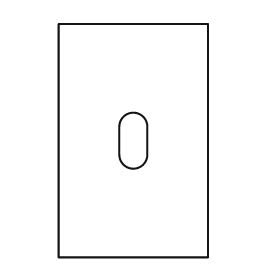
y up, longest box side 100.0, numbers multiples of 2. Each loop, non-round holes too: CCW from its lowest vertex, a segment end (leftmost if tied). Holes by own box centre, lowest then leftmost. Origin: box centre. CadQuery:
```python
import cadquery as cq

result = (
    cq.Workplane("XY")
    .moveTo(-32.0, -50.0)
    .lineTo(32.0, -50.0)
    .lineTo(32.0, 50.0)
    .lineTo(-32.0, 50.0)
    .close()
    .moveTo(-6.0, -6.0)
    .threePointArc((0.0, -12.0), (6.0, -6.0))
    .lineTo(6.0, 6.0)
    .threePointArc((0.0, 12.0), (-6.0, 6.0))
    .close()
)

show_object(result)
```